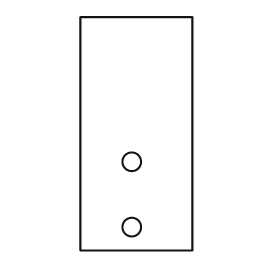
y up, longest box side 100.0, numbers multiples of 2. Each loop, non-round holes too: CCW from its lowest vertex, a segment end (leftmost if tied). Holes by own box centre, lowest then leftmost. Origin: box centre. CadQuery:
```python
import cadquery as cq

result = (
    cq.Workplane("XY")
    .moveTo(-24.0, -50.0)
    .lineTo(24.0, -50.0)
    .lineTo(24.0, 50.0)
    .lineTo(-24.0, 50.0)
    .close()
    .moveTo(-2.0, -40.0)
    .circle(4.0)
    .moveTo(-2.0, -12.0)
    .circle(4.0)
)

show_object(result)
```